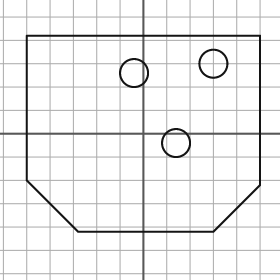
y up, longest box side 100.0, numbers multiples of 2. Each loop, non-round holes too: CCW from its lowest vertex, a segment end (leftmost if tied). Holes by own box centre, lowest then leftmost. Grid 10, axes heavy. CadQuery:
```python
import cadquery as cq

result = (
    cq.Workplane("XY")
    .moveTo(-28.0, -42.0)
    .lineTo(30.0, -42.0)
    .lineTo(50.0, -22.0)
    .lineTo(50.0, 42.0)
    .lineTo(-50.0, 42.0)
    .lineTo(-50.0, -20.0)
    .close()
    .moveTo(14.0, -4.0)
    .circle(6.0)
    .moveTo(-4.0, 26.0)
    .circle(6.0)
    .moveTo(30.0, 30.0)
    .circle(6.0)
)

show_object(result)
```